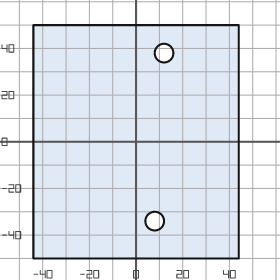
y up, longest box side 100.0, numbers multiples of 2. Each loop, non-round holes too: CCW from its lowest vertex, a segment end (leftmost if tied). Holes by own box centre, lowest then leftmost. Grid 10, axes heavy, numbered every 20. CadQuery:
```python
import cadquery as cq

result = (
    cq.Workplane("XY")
    .moveTo(-44.0, -50.0)
    .lineTo(44.0, -50.0)
    .lineTo(44.0, 50.0)
    .lineTo(-44.0, 50.0)
    .close()
    .moveTo(8.0, -34.0)
    .circle(4.0)
    .moveTo(12.0, 38.0)
    .circle(4.0)
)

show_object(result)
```